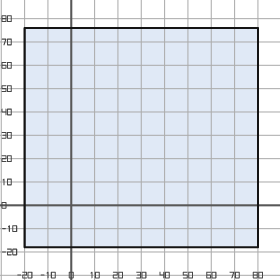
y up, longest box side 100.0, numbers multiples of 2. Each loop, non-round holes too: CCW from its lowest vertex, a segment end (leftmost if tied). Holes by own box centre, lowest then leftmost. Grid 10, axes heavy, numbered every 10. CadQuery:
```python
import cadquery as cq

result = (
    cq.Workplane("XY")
    .moveTo(-20.0, -18.0)
    .lineTo(80.0, -18.0)
    .lineTo(80.0, 76.0)
    .lineTo(-20.0, 76.0)
    .close()
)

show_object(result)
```